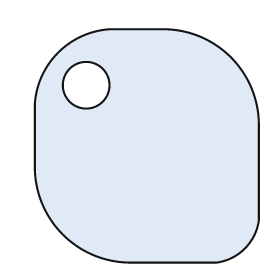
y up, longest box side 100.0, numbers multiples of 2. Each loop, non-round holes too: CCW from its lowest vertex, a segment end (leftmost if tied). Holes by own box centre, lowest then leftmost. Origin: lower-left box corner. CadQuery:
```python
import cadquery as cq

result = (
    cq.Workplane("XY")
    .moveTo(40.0, 0.0)
    .lineTo(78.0, 0.0)
    .threePointArc((90.0, 6.0), (96.0, 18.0))
    .lineTo(96.0, 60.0)
    .threePointArc((84.0, 88.0), (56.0, 100.0))
    .lineTo(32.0, 100.0)
    .threePointArc((10.0, 90.0), (0.0, 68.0))
    .lineTo(0.0, 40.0)
    .threePointArc((12.0, 12.0), (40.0, 0.0))
    .close()
    .moveTo(22.0, 76.0)
    .circle(10.0)
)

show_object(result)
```